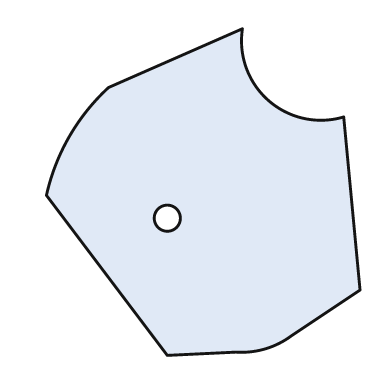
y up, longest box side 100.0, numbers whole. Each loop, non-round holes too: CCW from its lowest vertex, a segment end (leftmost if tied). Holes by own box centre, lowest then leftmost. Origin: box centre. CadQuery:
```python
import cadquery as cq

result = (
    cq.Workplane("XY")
    .moveTo(-11.0, -50.0)
    .lineTo(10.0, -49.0)
    .threePointArc((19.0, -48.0), (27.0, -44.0))
    .lineTo(48.0, -30.0)
    .lineTo(43.0, 23.0)
    .threePointArc((20.0, 28.0), (12.0, 50.0))
    .lineTo(-29.0, 32.0)
    .threePointArc((-41.0, 17.0), (-48.0, -1.0))
    .close()
    .moveTo(-11.0, -8.0)
    .circle(4.0)
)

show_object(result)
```